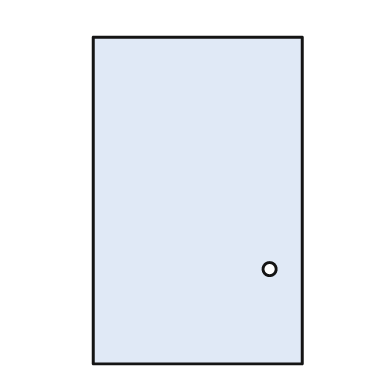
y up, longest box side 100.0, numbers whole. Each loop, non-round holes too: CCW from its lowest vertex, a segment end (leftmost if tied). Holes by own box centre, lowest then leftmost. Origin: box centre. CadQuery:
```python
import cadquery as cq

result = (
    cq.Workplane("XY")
    .moveTo(-32.0, -50.0)
    .lineTo(32.0, -50.0)
    .lineTo(32.0, 50.0)
    .lineTo(-32.0, 50.0)
    .close()
    .moveTo(22.0, -21.0)
    .circle(2.0)
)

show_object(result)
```